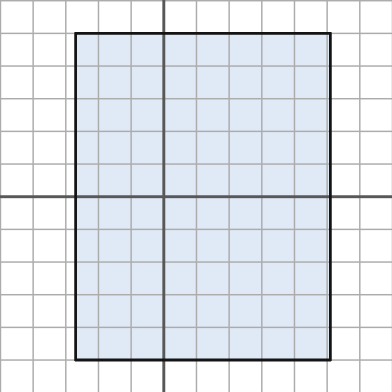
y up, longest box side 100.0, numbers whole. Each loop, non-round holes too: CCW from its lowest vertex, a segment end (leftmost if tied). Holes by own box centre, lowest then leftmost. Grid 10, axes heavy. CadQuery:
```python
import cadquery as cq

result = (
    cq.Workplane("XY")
    .moveTo(-27.0, -50.0)
    .lineTo(51.0, -50.0)
    .lineTo(51.0, 50.0)
    .lineTo(-27.0, 50.0)
    .close()
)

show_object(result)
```